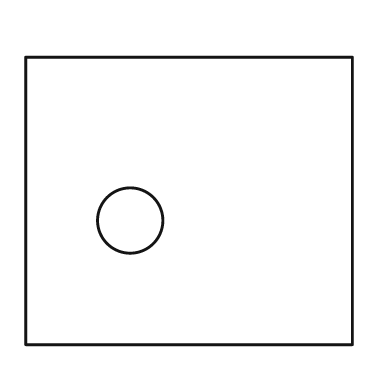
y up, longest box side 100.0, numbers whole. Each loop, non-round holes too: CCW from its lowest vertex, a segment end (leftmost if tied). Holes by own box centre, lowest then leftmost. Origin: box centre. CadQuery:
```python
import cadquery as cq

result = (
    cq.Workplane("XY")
    .moveTo(-50.0, -44.0)
    .lineTo(50.0, -44.0)
    .lineTo(50.0, 44.0)
    .lineTo(-50.0, 44.0)
    .close()
    .moveTo(-18.0, -6.0)
    .circle(10.0)
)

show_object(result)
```